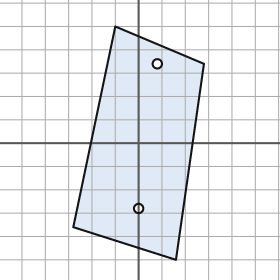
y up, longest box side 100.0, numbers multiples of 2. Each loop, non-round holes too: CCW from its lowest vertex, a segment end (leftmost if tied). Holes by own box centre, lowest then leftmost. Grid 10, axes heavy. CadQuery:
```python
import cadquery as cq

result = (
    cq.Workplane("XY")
    .moveTo(16.0, -50.0)
    .lineTo(28.0, 34.0)
    .lineTo(-10.0, 50.0)
    .lineTo(-28.0, -36.0)
    .close()
    .moveTo(0.0, -28.0)
    .circle(2.0)
    .moveTo(8.0, 34.0)
    .circle(2.0)
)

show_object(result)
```